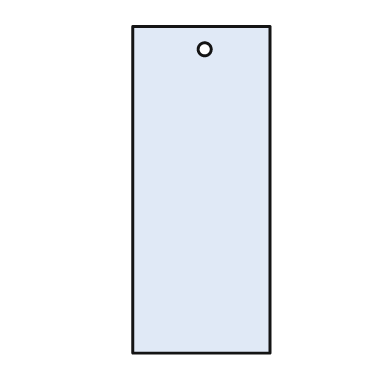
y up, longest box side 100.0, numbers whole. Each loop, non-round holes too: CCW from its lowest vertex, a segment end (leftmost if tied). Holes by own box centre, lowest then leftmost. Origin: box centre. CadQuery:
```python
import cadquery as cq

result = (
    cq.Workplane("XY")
    .moveTo(-21.0, -50.0)
    .lineTo(21.0, -50.0)
    .lineTo(21.0, 50.0)
    .lineTo(-21.0, 50.0)
    .close()
    .moveTo(1.0, 43.0)
    .circle(2.0)
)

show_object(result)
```